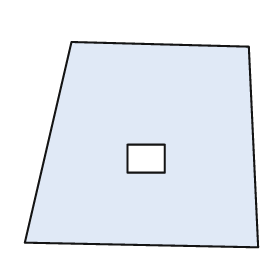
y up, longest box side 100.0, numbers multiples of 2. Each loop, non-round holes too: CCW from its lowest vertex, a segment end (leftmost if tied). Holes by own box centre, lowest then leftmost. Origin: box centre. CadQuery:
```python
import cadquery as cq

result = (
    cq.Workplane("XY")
    .moveTo(50.0, -44.0)
    .lineTo(46.0, 42.0)
    .lineTo(-30.0, 44.0)
    .lineTo(-50.0, -42.0)
    .close()
    .moveTo(-6.0, -12.0)
    .lineTo(10.0, -12.0)
    .lineTo(10.0, 0.0)
    .lineTo(-6.0, 0.0)
    .close()
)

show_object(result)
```